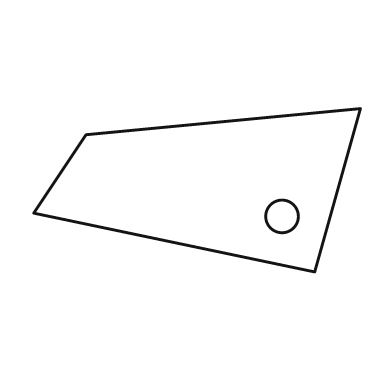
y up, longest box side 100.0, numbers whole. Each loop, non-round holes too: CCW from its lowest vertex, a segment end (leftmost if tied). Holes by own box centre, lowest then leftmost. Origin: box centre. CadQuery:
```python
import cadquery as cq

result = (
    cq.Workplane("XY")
    .moveTo(36.0, -25.0)
    .lineTo(50.0, 25.0)
    .lineTo(-34.0, 17.0)
    .lineTo(-50.0, -7.0)
    .close()
    .moveTo(26.0, -8.0)
    .circle(5.0)
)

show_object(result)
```